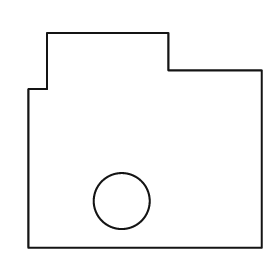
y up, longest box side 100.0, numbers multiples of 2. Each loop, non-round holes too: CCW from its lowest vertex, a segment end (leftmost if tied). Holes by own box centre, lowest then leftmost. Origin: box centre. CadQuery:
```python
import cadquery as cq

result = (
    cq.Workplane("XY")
    .moveTo(-50.0, -46.0)
    .lineTo(50.0, -46.0)
    .lineTo(50.0, 30.0)
    .lineTo(10.0, 30.0)
    .lineTo(10.0, 46.0)
    .lineTo(-42.0, 46.0)
    .lineTo(-42.0, 22.0)
    .lineTo(-50.0, 22.0)
    .close()
    .moveTo(-10.0, -26.0)
    .circle(12.0)
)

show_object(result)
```